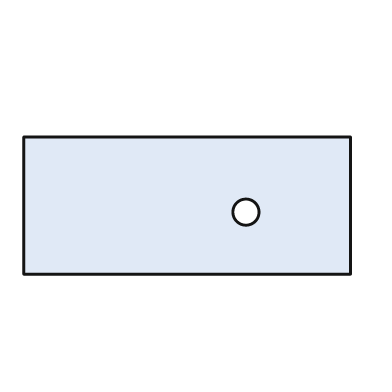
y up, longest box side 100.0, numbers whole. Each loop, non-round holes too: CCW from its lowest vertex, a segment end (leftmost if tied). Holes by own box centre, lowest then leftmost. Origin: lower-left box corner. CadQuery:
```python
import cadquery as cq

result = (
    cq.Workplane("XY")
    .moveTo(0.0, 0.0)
    .lineTo(100.0, 0.0)
    .lineTo(100.0, 42.0)
    .lineTo(0.0, 42.0)
    .close()
    .moveTo(68.0, 19.0)
    .circle(4.0)
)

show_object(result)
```